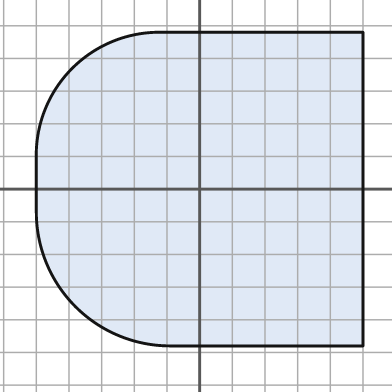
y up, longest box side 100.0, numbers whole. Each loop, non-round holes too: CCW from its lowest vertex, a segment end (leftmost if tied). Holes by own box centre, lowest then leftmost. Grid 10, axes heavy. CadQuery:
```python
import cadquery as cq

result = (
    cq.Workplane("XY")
    .moveTo(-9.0, -48.0)
    .lineTo(50.0, -48.0)
    .lineTo(50.0, 48.0)
    .lineTo(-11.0, 48.0)
    .threePointArc((-39.0, 37.0), (-50.0, 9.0))
    .lineTo(-50.0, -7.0)
    .threePointArc((-38.0, -36.0), (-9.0, -48.0))
    .close()
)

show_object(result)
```